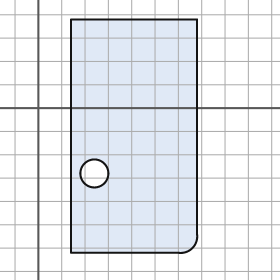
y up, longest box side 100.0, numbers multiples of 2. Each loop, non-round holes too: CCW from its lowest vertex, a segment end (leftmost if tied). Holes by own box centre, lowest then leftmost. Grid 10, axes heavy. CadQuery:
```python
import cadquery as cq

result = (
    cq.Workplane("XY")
    .moveTo(14.0, -62.0)
    .lineTo(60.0, -62.0)
    .threePointArc((66.0, -60.0), (68.0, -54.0))
    .lineTo(68.0, 38.0)
    .lineTo(14.0, 38.0)
    .close()
    .moveTo(24.0, -28.0)
    .circle(6.0)
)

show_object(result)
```